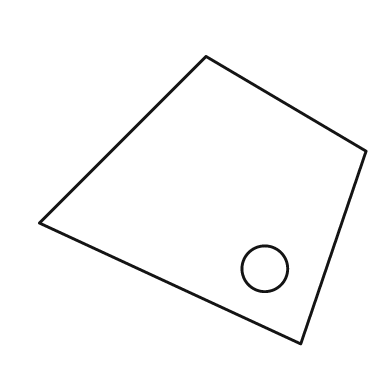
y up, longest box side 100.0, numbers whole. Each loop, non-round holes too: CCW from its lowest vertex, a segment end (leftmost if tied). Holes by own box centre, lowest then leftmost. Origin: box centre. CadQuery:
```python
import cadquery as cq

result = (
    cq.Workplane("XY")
    .moveTo(30.0, -44.0)
    .lineTo(50.0, 15.0)
    .lineTo(1.0, 44.0)
    .lineTo(-50.0, -7.0)
    .close()
    .moveTo(19.0, -21.0)
    .circle(7.0)
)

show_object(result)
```